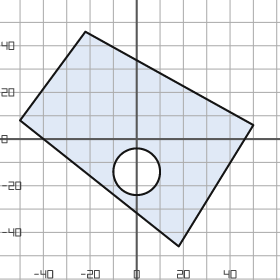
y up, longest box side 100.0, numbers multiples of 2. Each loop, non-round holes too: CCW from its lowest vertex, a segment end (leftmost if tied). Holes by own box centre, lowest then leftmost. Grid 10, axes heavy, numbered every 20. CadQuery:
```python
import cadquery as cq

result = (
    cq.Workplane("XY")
    .moveTo(18.0, -46.0)
    .lineTo(50.0, 6.0)
    .lineTo(-22.0, 46.0)
    .lineTo(-50.0, 8.0)
    .close()
    .moveTo(0.0, -14.0)
    .circle(10.0)
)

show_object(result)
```